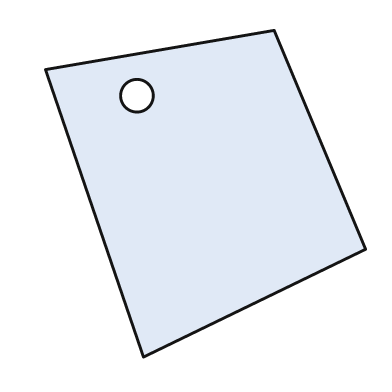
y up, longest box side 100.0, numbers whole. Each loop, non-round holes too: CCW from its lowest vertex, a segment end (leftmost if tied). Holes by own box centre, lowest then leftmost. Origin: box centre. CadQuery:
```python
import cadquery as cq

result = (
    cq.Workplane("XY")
    .moveTo(-19.0, -50.0)
    .lineTo(49.0, -17.0)
    .lineTo(21.0, 50.0)
    .lineTo(-49.0, 38.0)
    .close()
    .moveTo(-21.0, 30.0)
    .circle(5.0)
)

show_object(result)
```